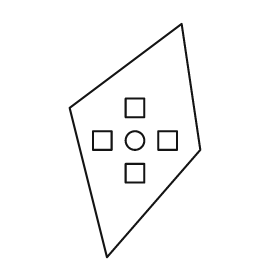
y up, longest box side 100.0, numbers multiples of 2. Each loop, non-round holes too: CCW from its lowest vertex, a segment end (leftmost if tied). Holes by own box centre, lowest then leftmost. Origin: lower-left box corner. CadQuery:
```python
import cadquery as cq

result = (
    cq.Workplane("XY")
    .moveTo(16.0, 0.0)
    .lineTo(56.0, 46.0)
    .lineTo(48.0, 100.0)
    .lineTo(0.0, 64.0)
    .close()
    .moveTo(24.0, 32.0)
    .lineTo(32.0, 32.0)
    .lineTo(32.0, 40.0)
    .lineTo(24.0, 40.0)
    .close()
    .moveTo(10.0, 46.0)
    .lineTo(18.0, 46.0)
    .lineTo(18.0, 54.0)
    .lineTo(10.0, 54.0)
    .close()
    .moveTo(28.0, 50.0)
    .circle(4.0)
    .moveTo(38.0, 46.0)
    .lineTo(46.0, 46.0)
    .lineTo(46.0, 54.0)
    .lineTo(38.0, 54.0)
    .close()
    .moveTo(24.0, 60.0)
    .lineTo(32.0, 60.0)
    .lineTo(32.0, 68.0)
    .lineTo(24.0, 68.0)
    .close()
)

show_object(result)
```